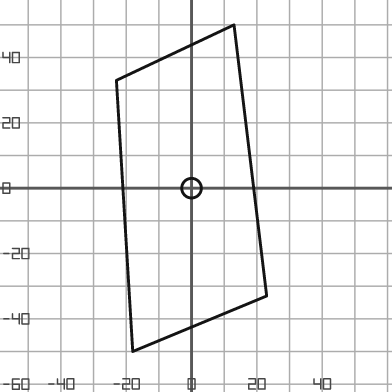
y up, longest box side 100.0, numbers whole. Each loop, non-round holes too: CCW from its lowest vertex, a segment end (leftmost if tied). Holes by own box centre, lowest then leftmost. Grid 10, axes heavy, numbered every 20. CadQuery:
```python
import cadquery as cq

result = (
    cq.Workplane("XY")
    .moveTo(-18.0, -50.0)
    .lineTo(23.0, -33.0)
    .lineTo(13.0, 50.0)
    .lineTo(-23.0, 33.0)
    .close()
    .moveTo(0.0, 0.0)
    .circle(3.0)
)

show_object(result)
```